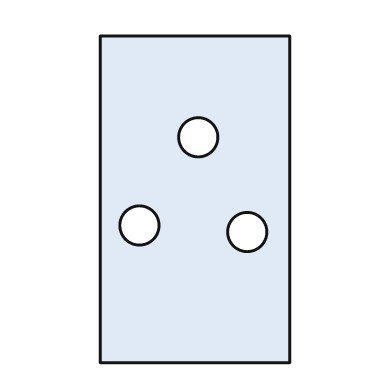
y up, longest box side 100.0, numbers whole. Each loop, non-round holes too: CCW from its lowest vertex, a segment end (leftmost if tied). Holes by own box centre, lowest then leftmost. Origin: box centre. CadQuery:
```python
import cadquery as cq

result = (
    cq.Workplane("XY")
    .moveTo(-29.0, -50.0)
    .lineTo(29.0, -50.0)
    .lineTo(29.0, 50.0)
    .lineTo(-29.0, 50.0)
    .close()
    .moveTo(16.0, -10.0)
    .circle(6.0)
    .moveTo(-17.0, -8.0)
    .circle(6.0)
    .moveTo(1.0, 19.0)
    .circle(6.0)
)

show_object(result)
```